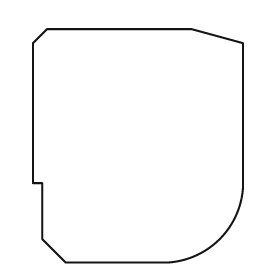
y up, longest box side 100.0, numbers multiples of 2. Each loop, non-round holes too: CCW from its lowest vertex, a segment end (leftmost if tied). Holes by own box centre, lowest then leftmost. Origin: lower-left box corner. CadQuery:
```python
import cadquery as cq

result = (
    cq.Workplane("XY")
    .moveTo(14.0, 0.0)
    .lineTo(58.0, 0.0)
    .threePointArc((80.0, 10.0), (90.0, 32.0))
    .lineTo(90.0, 94.0)
    .lineTo(68.0, 100.0)
    .lineTo(6.0, 100.0)
    .lineTo(0.0, 94.0)
    .lineTo(0.0, 34.0)
    .lineTo(4.0, 34.0)
    .lineTo(4.0, 10.0)
    .close()
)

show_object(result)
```